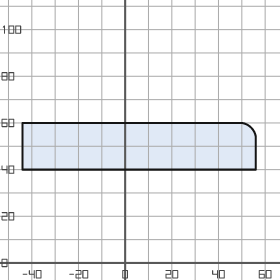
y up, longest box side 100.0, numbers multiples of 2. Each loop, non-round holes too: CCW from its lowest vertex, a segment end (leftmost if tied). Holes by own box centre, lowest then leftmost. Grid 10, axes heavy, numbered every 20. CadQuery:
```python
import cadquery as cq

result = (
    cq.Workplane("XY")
    .moveTo(-44.0, 40.0)
    .lineTo(56.0, 40.0)
    .lineTo(56.0, 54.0)
    .threePointArc((54.0, 58.0), (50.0, 60.0))
    .lineTo(-44.0, 60.0)
    .close()
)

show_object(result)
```